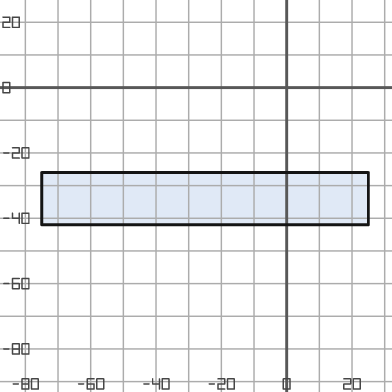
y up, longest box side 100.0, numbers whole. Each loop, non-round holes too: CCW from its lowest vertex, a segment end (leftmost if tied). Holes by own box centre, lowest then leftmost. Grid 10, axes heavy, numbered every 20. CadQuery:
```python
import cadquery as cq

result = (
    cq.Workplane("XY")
    .moveTo(-75.0, -42.0)
    .lineTo(25.0, -42.0)
    .lineTo(25.0, -26.0)
    .lineTo(-75.0, -26.0)
    .close()
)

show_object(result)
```